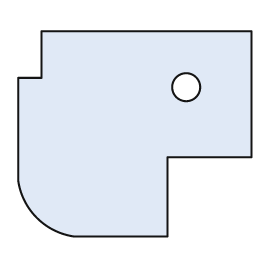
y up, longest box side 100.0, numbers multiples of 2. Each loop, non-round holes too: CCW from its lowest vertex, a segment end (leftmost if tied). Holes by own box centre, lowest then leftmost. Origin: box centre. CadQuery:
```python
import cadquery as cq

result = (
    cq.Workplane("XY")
    .moveTo(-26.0, -44.0)
    .lineTo(14.0, -44.0)
    .lineTo(14.0, -10.0)
    .lineTo(50.0, -10.0)
    .lineTo(50.0, 44.0)
    .lineTo(-40.0, 44.0)
    .lineTo(-40.0, 24.0)
    .lineTo(-50.0, 24.0)
    .lineTo(-50.0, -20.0)
    .threePointArc((-42.0, -36.0), (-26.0, -44.0))
    .close()
    .moveTo(22.0, 20.0)
    .circle(6.0)
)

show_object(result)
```